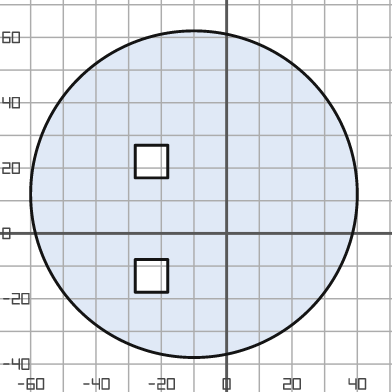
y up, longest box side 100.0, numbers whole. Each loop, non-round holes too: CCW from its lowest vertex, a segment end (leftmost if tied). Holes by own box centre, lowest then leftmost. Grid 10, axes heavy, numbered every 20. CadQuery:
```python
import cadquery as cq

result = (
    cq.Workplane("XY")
    .moveTo(-10.0, 12.0)
    .circle(50.0)
    .moveTo(-28.0, -18.0)
    .lineTo(-18.0, -18.0)
    .lineTo(-18.0, -8.0)
    .lineTo(-28.0, -8.0)
    .close()
    .moveTo(-28.0, 17.0)
    .lineTo(-18.0, 17.0)
    .lineTo(-18.0, 27.0)
    .lineTo(-28.0, 27.0)
    .close()
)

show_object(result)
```